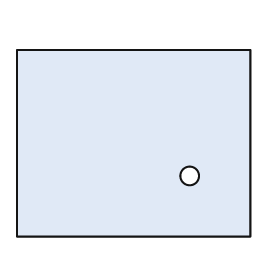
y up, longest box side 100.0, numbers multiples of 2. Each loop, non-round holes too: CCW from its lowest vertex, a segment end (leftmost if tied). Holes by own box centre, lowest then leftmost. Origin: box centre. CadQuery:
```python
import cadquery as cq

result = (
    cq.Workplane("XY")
    .moveTo(-50.0, -40.0)
    .lineTo(50.0, -40.0)
    .lineTo(50.0, 40.0)
    .lineTo(-50.0, 40.0)
    .close()
    .moveTo(24.0, -14.0)
    .circle(4.0)
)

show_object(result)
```